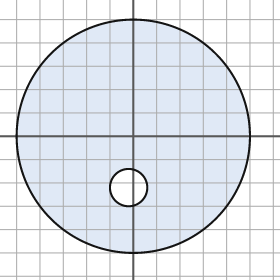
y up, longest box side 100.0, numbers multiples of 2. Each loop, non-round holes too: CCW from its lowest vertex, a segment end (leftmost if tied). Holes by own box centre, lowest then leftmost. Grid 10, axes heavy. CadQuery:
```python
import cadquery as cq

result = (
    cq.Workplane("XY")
    .moveTo(0.0, 0.0)
    .circle(50.0)
    .moveTo(-2.0, -22.0)
    .circle(8.0)
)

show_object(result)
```